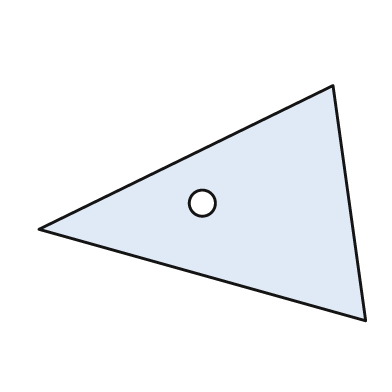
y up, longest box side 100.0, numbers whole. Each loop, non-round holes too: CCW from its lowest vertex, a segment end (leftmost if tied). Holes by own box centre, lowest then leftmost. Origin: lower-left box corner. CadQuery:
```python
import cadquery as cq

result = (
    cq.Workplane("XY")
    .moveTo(100.0, 0.0)
    .lineTo(90.0, 72.0)
    .lineTo(0.0, 28.0)
    .close()
    .moveTo(50.0, 36.0)
    .circle(4.0)
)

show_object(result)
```